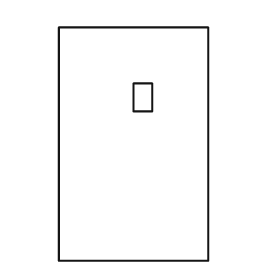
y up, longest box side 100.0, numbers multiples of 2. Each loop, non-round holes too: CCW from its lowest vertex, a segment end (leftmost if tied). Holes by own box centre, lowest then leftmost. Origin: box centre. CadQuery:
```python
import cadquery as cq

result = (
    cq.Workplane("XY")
    .moveTo(-32.0, -50.0)
    .lineTo(32.0, -50.0)
    .lineTo(32.0, 50.0)
    .lineTo(-32.0, 50.0)
    .close()
    .moveTo(0.0, 14.0)
    .lineTo(8.0, 14.0)
    .lineTo(8.0, 26.0)
    .lineTo(0.0, 26.0)
    .close()
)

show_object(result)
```